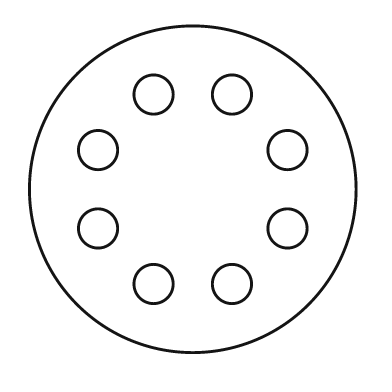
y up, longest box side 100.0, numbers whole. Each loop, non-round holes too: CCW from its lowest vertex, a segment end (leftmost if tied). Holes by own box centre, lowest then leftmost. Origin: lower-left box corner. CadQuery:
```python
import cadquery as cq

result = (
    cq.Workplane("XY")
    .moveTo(50.0, 50.0)
    .circle(50.0)
    .moveTo(38.0, 21.0)
    .circle(6.0)
    .moveTo(62.0, 21.0)
    .circle(6.0)
    .moveTo(21.0, 38.0)
    .circle(6.0)
    .moveTo(79.0, 38.0)
    .circle(6.0)
    .moveTo(21.0, 62.0)
    .circle(6.0)
    .moveTo(79.0, 62.0)
    .circle(6.0)
    .moveTo(38.0, 79.0)
    .circle(6.0)
    .moveTo(62.0, 79.0)
    .circle(6.0)
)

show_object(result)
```